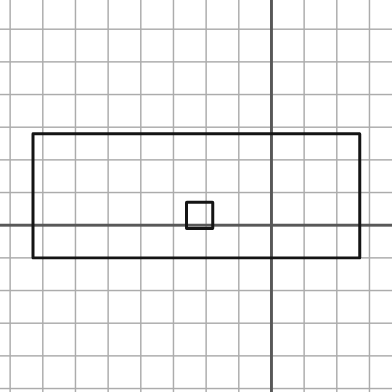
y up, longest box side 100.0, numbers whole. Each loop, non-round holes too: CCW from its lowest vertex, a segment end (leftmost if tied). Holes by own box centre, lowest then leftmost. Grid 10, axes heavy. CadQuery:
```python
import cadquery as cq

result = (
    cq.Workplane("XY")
    .moveTo(-73.0, -10.0)
    .lineTo(27.0, -10.0)
    .lineTo(27.0, 28.0)
    .lineTo(-73.0, 28.0)
    .close()
    .moveTo(-26.0, -1.0)
    .lineTo(-18.0, -1.0)
    .lineTo(-18.0, 7.0)
    .lineTo(-26.0, 7.0)
    .close()
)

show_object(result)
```